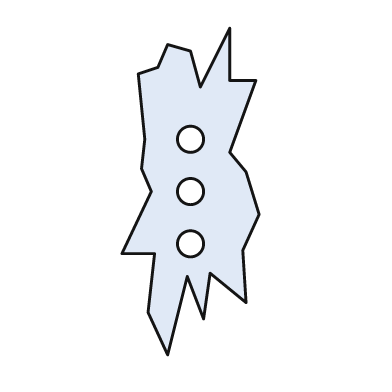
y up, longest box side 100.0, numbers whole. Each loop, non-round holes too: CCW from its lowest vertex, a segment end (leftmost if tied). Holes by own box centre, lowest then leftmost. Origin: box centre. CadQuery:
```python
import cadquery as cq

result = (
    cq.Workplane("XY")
    .moveTo(-7.0, -50.0)
    .lineTo(-1.0, -26.0)
    .lineTo(4.0, -39.0)
    .lineTo(6.0, -25.0)
    .lineTo(17.0, -34.0)
    .lineTo(16.0, -18.0)
    .lineTo(21.0, -7.0)
    .lineTo(17.0, 6.0)
    .lineTo(12.0, 12.0)
    .lineTo(20.0, 34.0)
    .lineTo(12.0, 34.0)
    .lineTo(12.0, 50.0)
    .lineTo(3.0, 32.0)
    .lineTo(0.0, 43.0)
    .lineTo(-7.0, 45.0)
    .lineTo(-10.0, 38.0)
    .lineTo(-16.0, 36.0)
    .lineTo(-14.0, 16.0)
    .lineTo(-15.0, 7.0)
    .lineTo(-12.0, 0.0)
    .lineTo(-21.0, -19.0)
    .lineTo(-11.0, -19.0)
    .lineTo(-13.0, -37.0)
    .close()
    .moveTo(0.0, -16.0)
    .circle(4.0)
    .moveTo(0.0, 0.0)
    .circle(4.0)
    .moveTo(0.0, 16.0)
    .circle(4.0)
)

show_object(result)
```